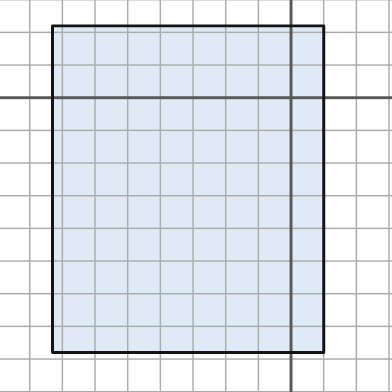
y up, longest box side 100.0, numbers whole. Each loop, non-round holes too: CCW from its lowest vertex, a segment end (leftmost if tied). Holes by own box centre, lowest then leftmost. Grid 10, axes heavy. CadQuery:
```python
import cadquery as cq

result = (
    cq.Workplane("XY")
    .moveTo(-73.0, -78.0)
    .lineTo(10.0, -78.0)
    .lineTo(10.0, 22.0)
    .lineTo(-73.0, 22.0)
    .close()
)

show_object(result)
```